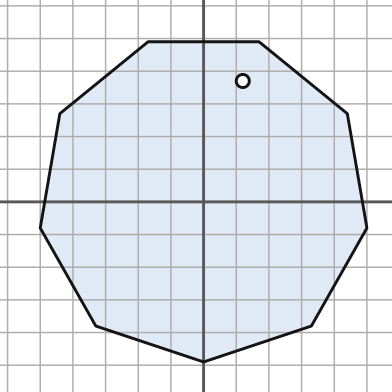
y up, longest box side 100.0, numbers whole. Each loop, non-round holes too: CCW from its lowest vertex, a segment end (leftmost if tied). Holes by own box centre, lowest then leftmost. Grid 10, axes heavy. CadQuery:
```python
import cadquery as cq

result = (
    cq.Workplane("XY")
    .moveTo(0.0, -49.0)
    .lineTo(33.0, -38.0)
    .lineTo(50.0, -8.0)
    .lineTo(44.0, 27.0)
    .lineTo(17.0, 49.0)
    .lineTo(-17.0, 49.0)
    .lineTo(-44.0, 27.0)
    .lineTo(-50.0, -8.0)
    .lineTo(-33.0, -38.0)
    .close()
    .moveTo(12.0, 37.0)
    .circle(2.0)
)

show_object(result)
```